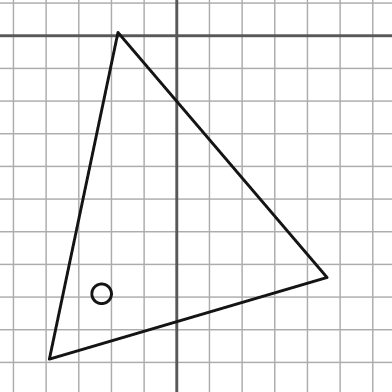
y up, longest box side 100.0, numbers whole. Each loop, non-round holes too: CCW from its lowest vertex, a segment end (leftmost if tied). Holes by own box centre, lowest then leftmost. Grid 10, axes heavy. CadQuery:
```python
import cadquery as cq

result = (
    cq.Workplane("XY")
    .moveTo(-39.0, -99.0)
    .lineTo(46.0, -74.0)
    .lineTo(-18.0, 1.0)
    .close()
    .moveTo(-23.0, -79.0)
    .circle(3.0)
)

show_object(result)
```